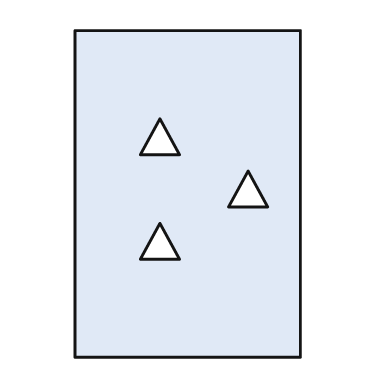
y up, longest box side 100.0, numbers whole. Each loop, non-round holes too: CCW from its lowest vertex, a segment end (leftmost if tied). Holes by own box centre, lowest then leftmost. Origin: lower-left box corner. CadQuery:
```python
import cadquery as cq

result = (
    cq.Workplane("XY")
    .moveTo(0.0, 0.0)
    .lineTo(69.0, 0.0)
    .lineTo(69.0, 100.0)
    .lineTo(0.0, 100.0)
    .close()
    .moveTo(20.0, 30.0)
    .lineTo(32.0, 30.0)
    .lineTo(26.0, 41.0)
    .close()
    .moveTo(47.0, 46.0)
    .lineTo(59.0, 46.0)
    .lineTo(53.0, 57.0)
    .close()
    .moveTo(20.0, 62.0)
    .lineTo(32.0, 62.0)
    .lineTo(26.0, 73.0)
    .close()
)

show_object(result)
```